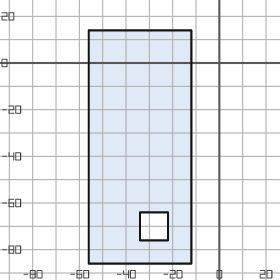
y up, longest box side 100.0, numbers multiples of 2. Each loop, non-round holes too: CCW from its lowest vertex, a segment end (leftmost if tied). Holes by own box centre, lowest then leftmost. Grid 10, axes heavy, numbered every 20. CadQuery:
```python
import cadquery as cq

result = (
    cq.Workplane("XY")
    .moveTo(-56.0, -86.0)
    .lineTo(-12.0, -86.0)
    .lineTo(-12.0, 14.0)
    .lineTo(-56.0, 14.0)
    .close()
    .moveTo(-34.0, -76.0)
    .lineTo(-22.0, -76.0)
    .lineTo(-22.0, -64.0)
    .lineTo(-34.0, -64.0)
    .close()
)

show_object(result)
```